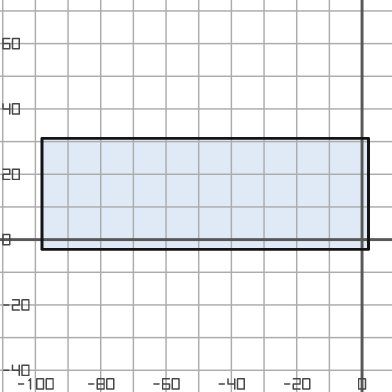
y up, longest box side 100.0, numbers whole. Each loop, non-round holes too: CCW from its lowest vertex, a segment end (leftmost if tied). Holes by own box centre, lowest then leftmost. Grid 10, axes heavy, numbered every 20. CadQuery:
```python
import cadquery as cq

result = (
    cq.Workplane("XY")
    .moveTo(-98.0, -3.0)
    .lineTo(2.0, -3.0)
    .lineTo(2.0, 31.0)
    .lineTo(-98.0, 31.0)
    .close()
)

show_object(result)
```